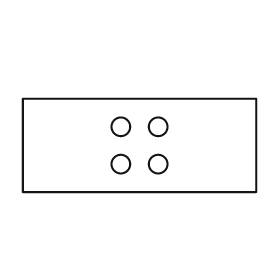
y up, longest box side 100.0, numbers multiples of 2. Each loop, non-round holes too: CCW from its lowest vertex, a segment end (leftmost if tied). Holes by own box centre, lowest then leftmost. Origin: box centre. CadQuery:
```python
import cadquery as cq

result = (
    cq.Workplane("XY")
    .moveTo(-50.0, -20.0)
    .lineTo(50.0, -20.0)
    .lineTo(50.0, 20.0)
    .lineTo(-50.0, 20.0)
    .close()
    .moveTo(-8.0, -8.0)
    .circle(4.0)
    .moveTo(8.0, -8.0)
    .circle(4.0)
    .moveTo(-8.0, 8.0)
    .circle(4.0)
    .moveTo(8.0, 8.0)
    .circle(4.0)
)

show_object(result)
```